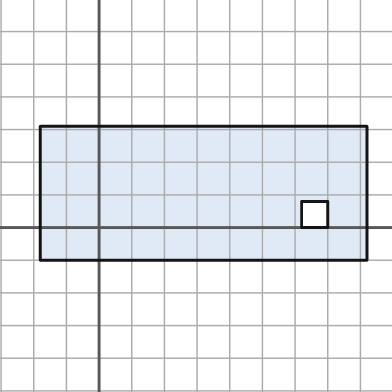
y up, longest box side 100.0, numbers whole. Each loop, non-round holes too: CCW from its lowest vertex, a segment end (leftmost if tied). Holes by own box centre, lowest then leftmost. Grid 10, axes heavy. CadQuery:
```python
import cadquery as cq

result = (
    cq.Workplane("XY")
    .moveTo(-18.0, -10.0)
    .lineTo(82.0, -10.0)
    .lineTo(82.0, 31.0)
    .lineTo(-18.0, 31.0)
    .close()
    .moveTo(62.0, 0.0)
    .lineTo(70.0, 0.0)
    .lineTo(70.0, 8.0)
    .lineTo(62.0, 8.0)
    .close()
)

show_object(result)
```